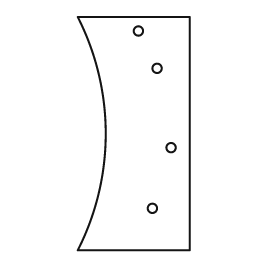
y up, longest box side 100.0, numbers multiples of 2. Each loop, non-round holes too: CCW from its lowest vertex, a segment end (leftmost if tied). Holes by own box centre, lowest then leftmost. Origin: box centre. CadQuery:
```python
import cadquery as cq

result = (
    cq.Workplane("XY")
    .moveTo(-24.0, -50.0)
    .lineTo(24.0, -50.0)
    .lineTo(24.0, 50.0)
    .lineTo(-24.0, 50.0)
    .threePointArc((-12.0, 0.0), (-24.0, -50.0))
    .close()
    .moveTo(8.0, -32.0)
    .circle(2.0)
    .moveTo(16.0, -6.0)
    .circle(2.0)
    .moveTo(10.0, 28.0)
    .circle(2.0)
    .moveTo(2.0, 44.0)
    .circle(2.0)
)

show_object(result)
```